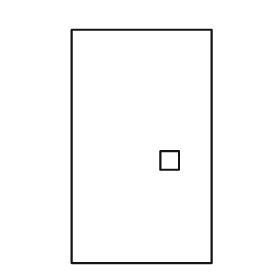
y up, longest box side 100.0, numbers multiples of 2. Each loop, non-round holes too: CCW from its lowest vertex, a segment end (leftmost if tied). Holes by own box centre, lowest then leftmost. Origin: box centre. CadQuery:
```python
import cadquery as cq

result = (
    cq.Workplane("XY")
    .moveTo(-30.0, -50.0)
    .lineTo(30.0, -50.0)
    .lineTo(30.0, 50.0)
    .lineTo(-30.0, 50.0)
    .close()
    .moveTo(8.0, -10.0)
    .lineTo(16.0, -10.0)
    .lineTo(16.0, -2.0)
    .lineTo(8.0, -2.0)
    .close()
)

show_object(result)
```